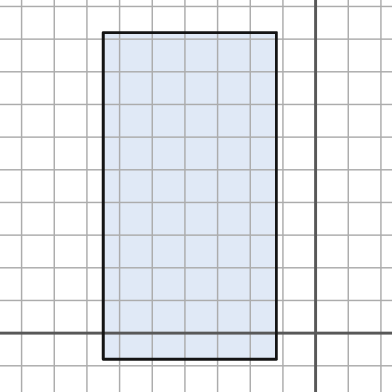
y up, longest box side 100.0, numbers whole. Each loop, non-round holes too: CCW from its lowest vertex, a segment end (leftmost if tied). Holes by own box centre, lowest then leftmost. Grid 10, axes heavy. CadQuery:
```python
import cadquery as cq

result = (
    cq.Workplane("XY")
    .moveTo(-65.0, -8.0)
    .lineTo(-12.0, -8.0)
    .lineTo(-12.0, 92.0)
    .lineTo(-65.0, 92.0)
    .close()
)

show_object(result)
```